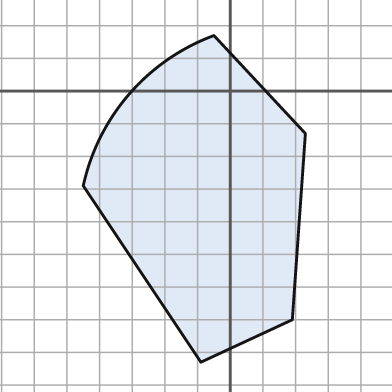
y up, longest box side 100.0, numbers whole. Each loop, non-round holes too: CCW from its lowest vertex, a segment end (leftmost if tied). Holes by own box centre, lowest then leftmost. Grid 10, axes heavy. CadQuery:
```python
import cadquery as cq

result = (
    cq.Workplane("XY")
    .moveTo(-9.0, -83.0)
    .lineTo(19.0, -70.0)
    .lineTo(23.0, -13.0)
    .lineTo(-5.0, 17.0)
    .threePointArc((-31.0, -1.0), (-45.0, -29.0))
    .close()
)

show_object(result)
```